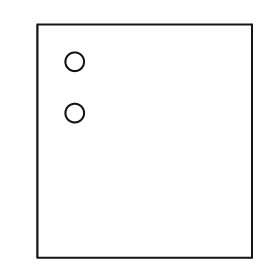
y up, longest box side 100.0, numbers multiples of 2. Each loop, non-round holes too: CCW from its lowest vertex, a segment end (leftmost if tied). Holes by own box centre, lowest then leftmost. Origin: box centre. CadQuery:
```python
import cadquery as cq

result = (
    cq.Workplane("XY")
    .moveTo(-46.0, -50.0)
    .lineTo(46.0, -50.0)
    .lineTo(46.0, 50.0)
    .lineTo(-46.0, 50.0)
    .close()
    .moveTo(-30.0, 12.0)
    .circle(4.0)
    .moveTo(-30.0, 34.0)
    .circle(4.0)
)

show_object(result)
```